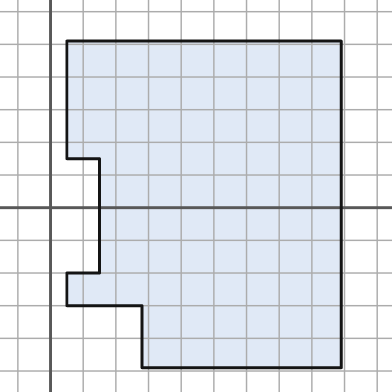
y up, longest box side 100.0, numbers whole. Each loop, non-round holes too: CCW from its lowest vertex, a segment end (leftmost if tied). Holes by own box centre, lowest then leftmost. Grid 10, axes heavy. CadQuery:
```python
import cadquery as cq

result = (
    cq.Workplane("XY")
    .moveTo(28.0, -49.0)
    .lineTo(89.0, -49.0)
    .lineTo(89.0, 51.0)
    .lineTo(5.0, 51.0)
    .lineTo(5.0, 15.0)
    .lineTo(15.0, 15.0)
    .lineTo(15.0, -20.0)
    .lineTo(5.0, -20.0)
    .lineTo(5.0, -30.0)
    .lineTo(28.0, -30.0)
    .close()
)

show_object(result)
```